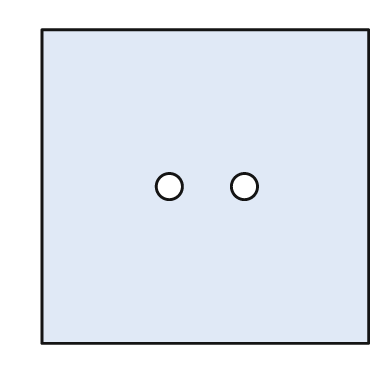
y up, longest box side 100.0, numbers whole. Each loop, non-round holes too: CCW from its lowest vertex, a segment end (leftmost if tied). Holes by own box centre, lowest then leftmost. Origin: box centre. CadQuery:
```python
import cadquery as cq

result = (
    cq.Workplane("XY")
    .moveTo(-50.0, -48.0)
    .lineTo(50.0, -48.0)
    .lineTo(50.0, 48.0)
    .lineTo(-50.0, 48.0)
    .close()
    .moveTo(-11.0, 0.0)
    .circle(4.0)
    .moveTo(12.0, 0.0)
    .circle(4.0)
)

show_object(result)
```